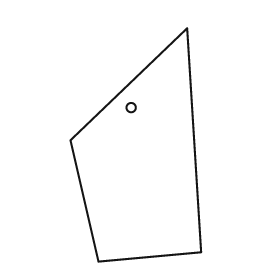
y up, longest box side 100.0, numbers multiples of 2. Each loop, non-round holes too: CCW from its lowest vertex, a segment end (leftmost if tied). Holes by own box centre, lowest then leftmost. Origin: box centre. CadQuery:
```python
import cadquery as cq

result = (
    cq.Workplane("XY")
    .moveTo(-16.0, -50.0)
    .lineTo(28.0, -46.0)
    .lineTo(22.0, 50.0)
    .lineTo(-28.0, 2.0)
    .close()
    .moveTo(-2.0, 16.0)
    .circle(2.0)
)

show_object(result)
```